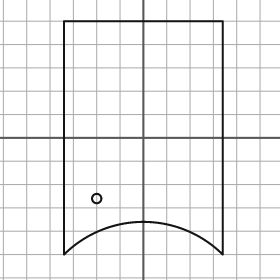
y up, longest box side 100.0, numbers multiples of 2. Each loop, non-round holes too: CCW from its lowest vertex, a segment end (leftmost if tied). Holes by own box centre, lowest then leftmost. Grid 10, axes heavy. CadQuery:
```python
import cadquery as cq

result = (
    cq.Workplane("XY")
    .moveTo(-34.0, -50.0)
    .threePointArc((0.0, -36.0), (34.0, -50.0))
    .lineTo(34.0, 50.0)
    .lineTo(-34.0, 50.0)
    .close()
    .moveTo(-20.0, -26.0)
    .circle(2.0)
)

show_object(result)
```